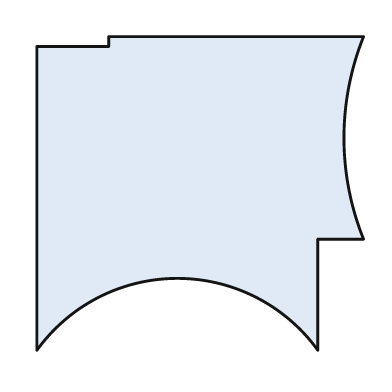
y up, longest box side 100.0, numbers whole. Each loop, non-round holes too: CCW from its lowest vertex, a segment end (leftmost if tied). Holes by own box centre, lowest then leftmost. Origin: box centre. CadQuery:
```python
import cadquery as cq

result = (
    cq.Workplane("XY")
    .moveTo(-50.0, -48.0)
    .threePointArc((-7.0, -26.0), (36.0, -48.0))
    .lineTo(36.0, -14.0)
    .lineTo(50.0, -14.0)
    .threePointArc((44.0, 17.0), (50.0, 48.0))
    .lineTo(-28.0, 48.0)
    .lineTo(-28.0, 45.0)
    .lineTo(-50.0, 45.0)
    .close()
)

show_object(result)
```